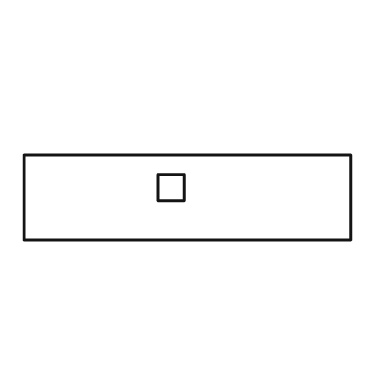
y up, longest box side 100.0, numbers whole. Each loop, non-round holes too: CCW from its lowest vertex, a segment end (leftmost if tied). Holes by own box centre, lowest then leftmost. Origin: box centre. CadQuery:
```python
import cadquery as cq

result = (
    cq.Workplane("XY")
    .moveTo(-50.0, -13.0)
    .lineTo(50.0, -13.0)
    .lineTo(50.0, 13.0)
    .lineTo(-50.0, 13.0)
    .close()
    .moveTo(-9.0, -1.0)
    .lineTo(-1.0, -1.0)
    .lineTo(-1.0, 7.0)
    .lineTo(-9.0, 7.0)
    .close()
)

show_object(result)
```